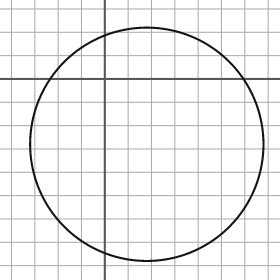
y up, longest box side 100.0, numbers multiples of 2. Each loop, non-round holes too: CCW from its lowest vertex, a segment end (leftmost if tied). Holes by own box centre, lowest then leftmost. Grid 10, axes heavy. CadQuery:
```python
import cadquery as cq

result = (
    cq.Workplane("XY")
    .moveTo(18.0, -28.0)
    .circle(50.0)
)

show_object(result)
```